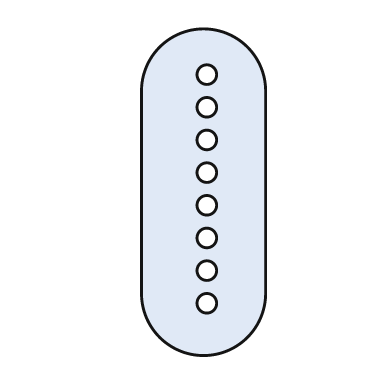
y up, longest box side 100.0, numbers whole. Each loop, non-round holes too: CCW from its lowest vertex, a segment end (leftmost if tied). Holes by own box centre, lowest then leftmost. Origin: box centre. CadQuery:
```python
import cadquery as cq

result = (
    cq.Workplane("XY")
    .moveTo(-19.0, -31.0)
    .threePointArc((0.0, -50.0), (19.0, -31.0))
    .lineTo(19.0, 31.0)
    .threePointArc((0.0, 50.0), (-19.0, 31.0))
    .close()
    .moveTo(1.0, -34.0)
    .circle(3.0)
    .moveTo(1.0, -24.0)
    .circle(3.0)
    .moveTo(1.0, -14.0)
    .circle(3.0)
    .moveTo(1.0, -4.0)
    .circle(3.0)
    .moveTo(1.0, 6.0)
    .circle(3.0)
    .moveTo(1.0, 16.0)
    .circle(3.0)
    .moveTo(1.0, 26.0)
    .circle(3.0)
    .moveTo(1.0, 36.0)
    .circle(3.0)
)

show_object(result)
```